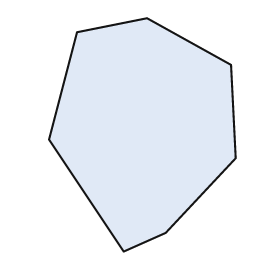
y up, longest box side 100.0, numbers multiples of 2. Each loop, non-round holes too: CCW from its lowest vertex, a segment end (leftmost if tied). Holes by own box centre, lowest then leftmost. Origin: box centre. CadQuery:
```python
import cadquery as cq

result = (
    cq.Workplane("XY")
    .moveTo(-8.0, -50.0)
    .lineTo(10.0, -42.0)
    .lineTo(40.0, -10.0)
    .lineTo(38.0, 30.0)
    .lineTo(2.0, 50.0)
    .lineTo(-28.0, 44.0)
    .lineTo(-40.0, -2.0)
    .close()
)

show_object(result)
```